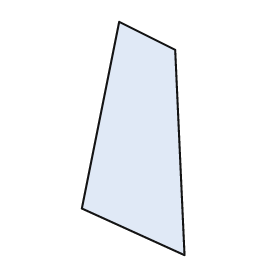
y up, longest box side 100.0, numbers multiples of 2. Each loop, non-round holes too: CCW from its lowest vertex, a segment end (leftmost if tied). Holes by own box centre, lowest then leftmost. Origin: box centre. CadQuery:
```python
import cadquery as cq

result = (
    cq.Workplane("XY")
    .moveTo(22.0, -50.0)
    .lineTo(18.0, 38.0)
    .lineTo(-6.0, 50.0)
    .lineTo(-22.0, -30.0)
    .close()
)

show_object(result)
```